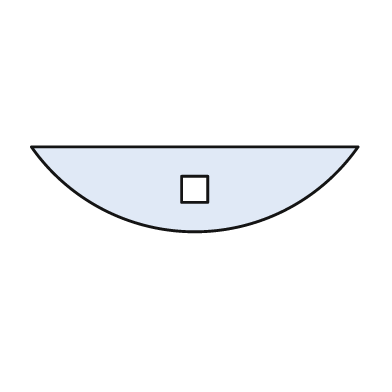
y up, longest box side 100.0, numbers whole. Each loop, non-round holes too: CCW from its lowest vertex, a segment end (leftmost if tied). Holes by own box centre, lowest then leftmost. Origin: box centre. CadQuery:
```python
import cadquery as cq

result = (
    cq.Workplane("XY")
    .moveTo(-50.0, 13.0)
    .threePointArc((0.0, -13.0), (50.0, 13.0))
    .close()
    .moveTo(-4.0, -4.0)
    .lineTo(4.0, -4.0)
    .lineTo(4.0, 4.0)
    .lineTo(-4.0, 4.0)
    .close()
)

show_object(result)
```